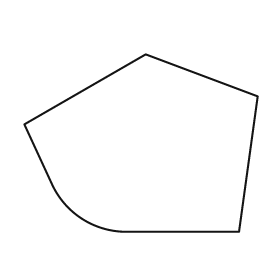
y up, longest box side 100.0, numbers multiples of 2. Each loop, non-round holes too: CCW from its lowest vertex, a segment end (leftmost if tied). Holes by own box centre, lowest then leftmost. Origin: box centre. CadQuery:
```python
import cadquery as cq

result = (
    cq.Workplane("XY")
    .moveTo(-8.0, -38.0)
    .lineTo(42.0, -38.0)
    .lineTo(50.0, 20.0)
    .lineTo(2.0, 38.0)
    .lineTo(-50.0, 8.0)
    .lineTo(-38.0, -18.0)
    .threePointArc((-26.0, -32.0), (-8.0, -38.0))
    .close()
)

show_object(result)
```